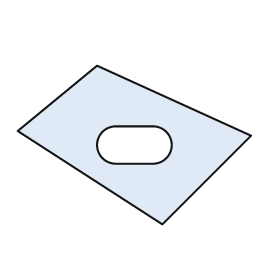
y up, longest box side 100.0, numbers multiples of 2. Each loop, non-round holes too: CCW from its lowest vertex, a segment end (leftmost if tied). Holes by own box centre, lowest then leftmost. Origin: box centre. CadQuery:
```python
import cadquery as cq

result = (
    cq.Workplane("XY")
    .moveTo(12.0, -34.0)
    .lineTo(50.0, 4.0)
    .lineTo(-16.0, 34.0)
    .lineTo(-50.0, 6.0)
    .close()
    .moveTo(-8.0, -8.0)
    .lineTo(8.0, -8.0)
    .threePointArc((16.0, 0.0), (8.0, 8.0))
    .lineTo(-8.0, 8.0)
    .threePointArc((-16.0, 0.0), (-8.0, -8.0))
    .close()
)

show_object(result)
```